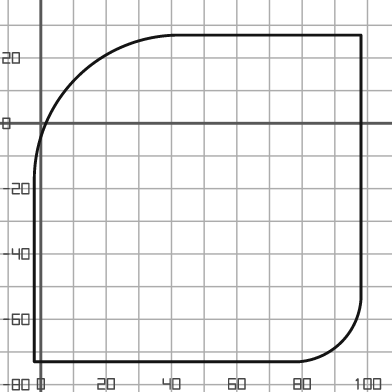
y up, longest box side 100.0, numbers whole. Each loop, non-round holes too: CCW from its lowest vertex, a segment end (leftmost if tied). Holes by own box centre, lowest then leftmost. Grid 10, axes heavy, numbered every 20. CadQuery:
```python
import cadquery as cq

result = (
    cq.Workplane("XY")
    .moveTo(-2.0, -73.0)
    .lineTo(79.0, -73.0)
    .threePointArc((92.0, -67.0), (98.0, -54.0))
    .lineTo(98.0, 27.0)
    .lineTo(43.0, 27.0)
    .threePointArc((11.0, 14.0), (-2.0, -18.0))
    .close()
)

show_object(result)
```